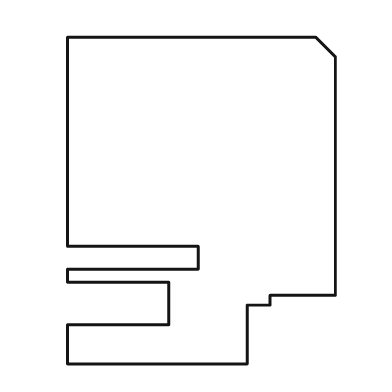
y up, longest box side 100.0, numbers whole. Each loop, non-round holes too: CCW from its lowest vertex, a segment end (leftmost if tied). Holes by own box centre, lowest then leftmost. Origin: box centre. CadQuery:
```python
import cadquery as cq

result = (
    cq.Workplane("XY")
    .moveTo(-41.0, -50.0)
    .lineTo(14.0, -50.0)
    .lineTo(14.0, -32.0)
    .lineTo(21.0, -32.0)
    .lineTo(21.0, -29.0)
    .lineTo(41.0, -29.0)
    .lineTo(41.0, 44.0)
    .lineTo(35.0, 50.0)
    .lineTo(-41.0, 50.0)
    .lineTo(-41.0, -14.0)
    .lineTo(-1.0, -14.0)
    .lineTo(-1.0, -21.0)
    .lineTo(-41.0, -21.0)
    .lineTo(-41.0, -25.0)
    .lineTo(-10.0, -25.0)
    .lineTo(-10.0, -38.0)
    .lineTo(-41.0, -38.0)
    .close()
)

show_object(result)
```